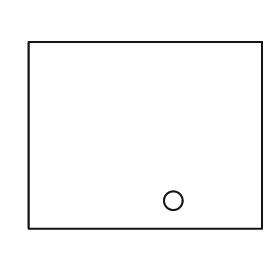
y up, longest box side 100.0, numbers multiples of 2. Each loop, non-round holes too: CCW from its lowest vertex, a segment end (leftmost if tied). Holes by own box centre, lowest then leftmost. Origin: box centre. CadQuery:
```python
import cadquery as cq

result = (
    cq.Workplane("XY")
    .moveTo(-50.0, -40.0)
    .lineTo(50.0, -40.0)
    .lineTo(50.0, 40.0)
    .lineTo(-50.0, 40.0)
    .close()
    .moveTo(12.0, -28.0)
    .circle(4.0)
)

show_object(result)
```